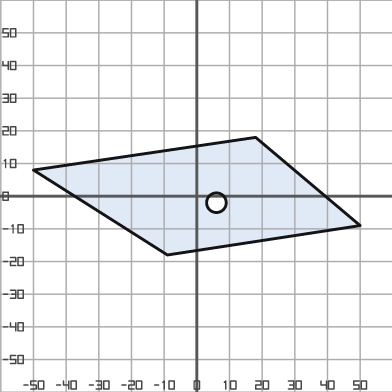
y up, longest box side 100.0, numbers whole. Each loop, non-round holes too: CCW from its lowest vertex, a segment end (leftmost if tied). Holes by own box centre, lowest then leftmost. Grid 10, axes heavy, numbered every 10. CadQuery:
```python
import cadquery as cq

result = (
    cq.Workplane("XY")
    .moveTo(-9.0, -18.0)
    .lineTo(50.0, -9.0)
    .lineTo(18.0, 18.0)
    .lineTo(-50.0, 8.0)
    .close()
    .moveTo(6.0, -2.0)
    .circle(3.0)
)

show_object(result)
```